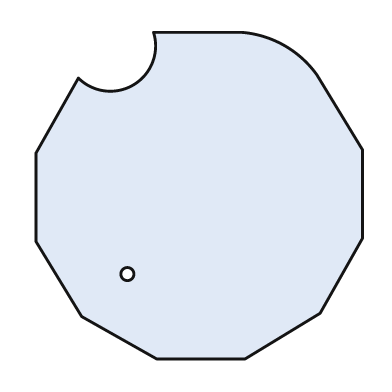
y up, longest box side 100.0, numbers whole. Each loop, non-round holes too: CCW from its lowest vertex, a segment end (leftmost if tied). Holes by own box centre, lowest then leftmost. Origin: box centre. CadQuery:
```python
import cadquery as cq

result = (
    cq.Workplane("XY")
    .moveTo(-13.0, -50.0)
    .lineTo(14.0, -50.0)
    .lineTo(37.0, -36.0)
    .lineTo(50.0, -13.0)
    .lineTo(50.0, 14.0)
    .lineTo(36.0, 37.0)
    .threePointArc((26.0, 46.0), (13.0, 50.0))
    .lineTo(-14.0, 50.0)
    .threePointArc((-20.0, 34.0), (-37.0, 36.0))
    .lineTo(-50.0, 13.0)
    .lineTo(-50.0, -14.0)
    .lineTo(-36.0, -37.0)
    .close()
    .moveTo(-22.0, -24.0)
    .circle(2.0)
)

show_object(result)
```